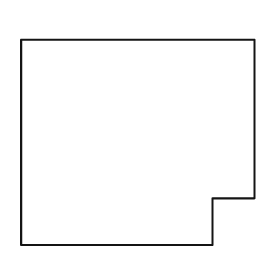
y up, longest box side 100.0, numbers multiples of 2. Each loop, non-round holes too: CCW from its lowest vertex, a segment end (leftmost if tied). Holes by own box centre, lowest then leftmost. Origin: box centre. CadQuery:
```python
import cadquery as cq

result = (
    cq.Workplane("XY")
    .moveTo(-50.0, -44.0)
    .lineTo(32.0, -44.0)
    .lineTo(32.0, -24.0)
    .lineTo(50.0, -24.0)
    .lineTo(50.0, 44.0)
    .lineTo(-50.0, 44.0)
    .close()
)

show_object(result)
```